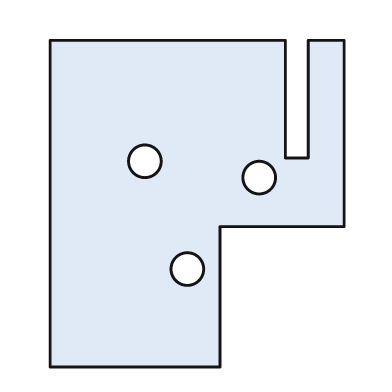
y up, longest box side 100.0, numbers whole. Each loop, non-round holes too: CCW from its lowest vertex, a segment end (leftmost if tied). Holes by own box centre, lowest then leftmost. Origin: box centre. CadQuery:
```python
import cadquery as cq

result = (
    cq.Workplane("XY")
    .moveTo(-45.0, -50.0)
    .lineTo(7.0, -50.0)
    .lineTo(7.0, -7.0)
    .lineTo(45.0, -7.0)
    .lineTo(45.0, 50.0)
    .lineTo(34.0, 50.0)
    .lineTo(34.0, 14.0)
    .lineTo(27.0, 14.0)
    .lineTo(27.0, 50.0)
    .lineTo(-45.0, 50.0)
    .close()
    .moveTo(-3.0, -20.0)
    .circle(5.0)
    .moveTo(19.0, 8.0)
    .circle(5.0)
    .moveTo(-16.0, 13.0)
    .circle(5.0)
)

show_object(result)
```